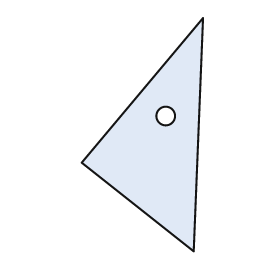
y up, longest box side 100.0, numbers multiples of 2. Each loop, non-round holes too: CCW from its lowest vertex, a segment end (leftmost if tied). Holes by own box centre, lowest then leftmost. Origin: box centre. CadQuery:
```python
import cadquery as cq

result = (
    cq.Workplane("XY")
    .moveTo(22.0, -50.0)
    .lineTo(26.0, 50.0)
    .lineTo(-26.0, -12.0)
    .close()
    .moveTo(10.0, 8.0)
    .circle(4.0)
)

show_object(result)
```